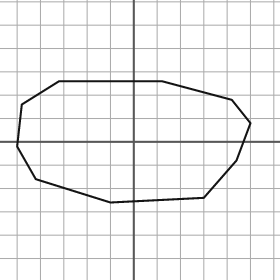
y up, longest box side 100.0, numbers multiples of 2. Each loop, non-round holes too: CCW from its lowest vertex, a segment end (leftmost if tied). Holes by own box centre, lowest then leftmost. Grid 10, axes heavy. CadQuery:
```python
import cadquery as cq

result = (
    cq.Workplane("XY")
    .moveTo(-10.0, -26.0)
    .lineTo(30.0, -24.0)
    .lineTo(44.0, -8.0)
    .lineTo(50.0, 8.0)
    .lineTo(42.0, 18.0)
    .lineTo(12.0, 26.0)
    .lineTo(-32.0, 26.0)
    .lineTo(-48.0, 16.0)
    .lineTo(-50.0, -2.0)
    .lineTo(-42.0, -16.0)
    .close()
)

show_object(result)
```